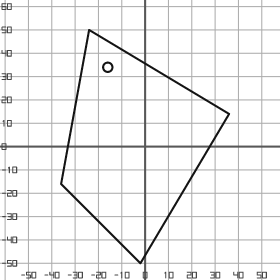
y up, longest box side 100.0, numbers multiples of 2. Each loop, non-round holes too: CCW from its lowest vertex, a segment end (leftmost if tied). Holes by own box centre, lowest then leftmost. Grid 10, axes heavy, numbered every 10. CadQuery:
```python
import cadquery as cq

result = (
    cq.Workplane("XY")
    .moveTo(-2.0, -50.0)
    .lineTo(36.0, 14.0)
    .lineTo(-24.0, 50.0)
    .lineTo(-36.0, -16.0)
    .close()
    .moveTo(-16.0, 34.0)
    .circle(2.0)
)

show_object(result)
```